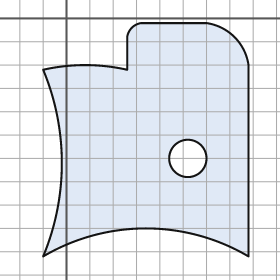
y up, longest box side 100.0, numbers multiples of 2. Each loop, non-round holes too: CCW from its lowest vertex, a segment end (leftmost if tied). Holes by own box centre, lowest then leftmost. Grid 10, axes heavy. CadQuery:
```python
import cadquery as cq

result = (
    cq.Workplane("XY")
    .moveTo(-10.0, -102.0)
    .threePointArc((34.0, -90.0), (78.0, -102.0))
    .lineTo(78.0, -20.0)
    .threePointArc((72.0, -8.0), (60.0, -2.0))
    .lineTo(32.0, -2.0)
    .threePointArc((28.0, -4.0), (26.0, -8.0))
    .lineTo(26.0, -22.0)
    .threePointArc((8.0, -20.0), (-10.0, -22.0))
    .threePointArc((-2.0, -62.0), (-10.0, -102.0))
    .close()
    .moveTo(52.0, -60.0)
    .circle(8.0)
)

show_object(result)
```